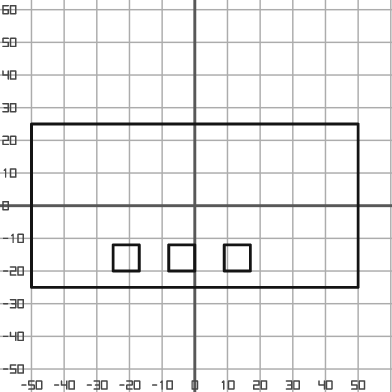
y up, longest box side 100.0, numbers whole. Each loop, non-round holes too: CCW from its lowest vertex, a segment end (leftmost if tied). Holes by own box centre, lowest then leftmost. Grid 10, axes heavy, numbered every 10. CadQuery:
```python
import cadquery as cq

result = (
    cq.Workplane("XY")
    .moveTo(-50.0, -25.0)
    .lineTo(50.0, -25.0)
    .lineTo(50.0, 25.0)
    .lineTo(-50.0, 25.0)
    .close()
    .moveTo(-25.0, -20.0)
    .lineTo(-17.0, -20.0)
    .lineTo(-17.0, -12.0)
    .lineTo(-25.0, -12.0)
    .close()
    .moveTo(-8.0, -20.0)
    .lineTo(0.0, -20.0)
    .lineTo(0.0, -12.0)
    .lineTo(-8.0, -12.0)
    .close()
    .moveTo(9.0, -20.0)
    .lineTo(17.0, -20.0)
    .lineTo(17.0, -12.0)
    .lineTo(9.0, -12.0)
    .close()
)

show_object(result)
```